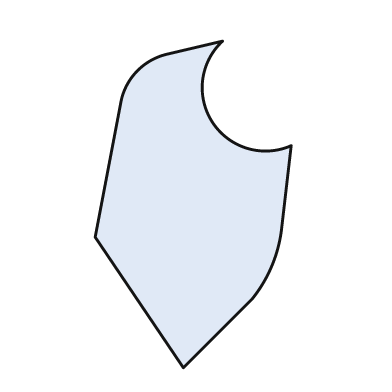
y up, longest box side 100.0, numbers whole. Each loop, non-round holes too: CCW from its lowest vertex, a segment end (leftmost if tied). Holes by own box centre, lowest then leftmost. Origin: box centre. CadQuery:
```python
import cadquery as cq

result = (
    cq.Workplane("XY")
    .moveTo(-3.0, -50.0)
    .lineTo(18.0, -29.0)
    .threePointArc((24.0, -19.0), (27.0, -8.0))
    .lineTo(30.0, 18.0)
    .threePointArc((6.0, 25.0), (9.0, 50.0))
    .lineTo(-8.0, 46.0)
    .threePointArc((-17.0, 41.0), (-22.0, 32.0))
    .lineTo(-30.0, -10.0)
    .close()
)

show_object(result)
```